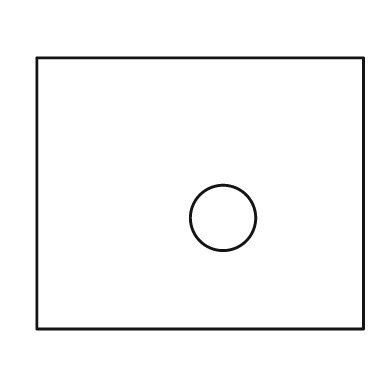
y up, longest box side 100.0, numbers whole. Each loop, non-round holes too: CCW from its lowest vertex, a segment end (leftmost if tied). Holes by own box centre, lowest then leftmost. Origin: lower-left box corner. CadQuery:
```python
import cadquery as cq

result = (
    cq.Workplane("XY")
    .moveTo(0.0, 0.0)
    .lineTo(100.0, 0.0)
    .lineTo(100.0, 83.0)
    .lineTo(0.0, 83.0)
    .close()
    .moveTo(57.0, 34.0)
    .circle(10.0)
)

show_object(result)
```